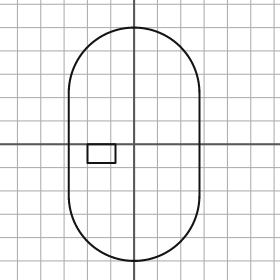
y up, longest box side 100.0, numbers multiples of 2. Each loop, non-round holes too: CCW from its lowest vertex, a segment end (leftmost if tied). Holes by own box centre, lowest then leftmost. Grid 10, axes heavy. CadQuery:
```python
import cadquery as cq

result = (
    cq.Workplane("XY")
    .moveTo(-28.0, -22.0)
    .threePointArc((0.0, -50.0), (28.0, -22.0))
    .lineTo(28.0, 22.0)
    .threePointArc((0.0, 50.0), (-28.0, 22.0))
    .close()
    .moveTo(-20.0, -8.0)
    .lineTo(-8.0, -8.0)
    .lineTo(-8.0, 0.0)
    .lineTo(-20.0, 0.0)
    .close()
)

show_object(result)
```